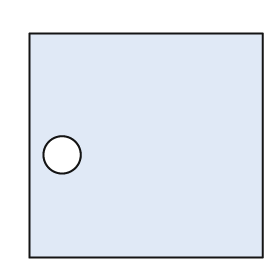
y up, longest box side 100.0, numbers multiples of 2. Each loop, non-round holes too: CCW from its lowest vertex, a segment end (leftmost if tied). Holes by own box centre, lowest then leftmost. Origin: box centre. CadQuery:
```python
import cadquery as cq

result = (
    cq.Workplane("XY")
    .moveTo(-50.0, -48.0)
    .lineTo(50.0, -48.0)
    .lineTo(50.0, 48.0)
    .lineTo(-50.0, 48.0)
    .close()
    .moveTo(-36.0, -4.0)
    .circle(8.0)
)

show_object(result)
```